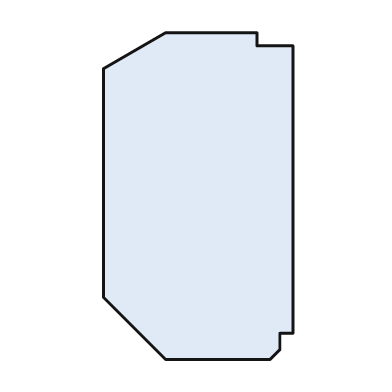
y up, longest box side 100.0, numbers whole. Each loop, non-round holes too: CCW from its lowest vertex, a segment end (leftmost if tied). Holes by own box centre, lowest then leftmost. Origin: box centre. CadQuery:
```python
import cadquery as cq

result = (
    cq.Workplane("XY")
    .moveTo(-10.0, -50.0)
    .lineTo(22.0, -50.0)
    .lineTo(25.0, -47.0)
    .lineTo(25.0, -42.0)
    .lineTo(29.0, -42.0)
    .lineTo(29.0, 46.0)
    .lineTo(18.0, 46.0)
    .lineTo(18.0, 50.0)
    .lineTo(-10.0, 50.0)
    .lineTo(-29.0, 39.0)
    .lineTo(-29.0, -31.0)
    .close()
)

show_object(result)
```